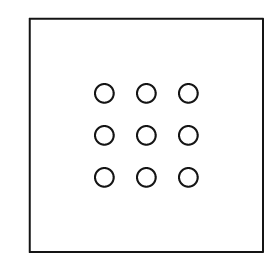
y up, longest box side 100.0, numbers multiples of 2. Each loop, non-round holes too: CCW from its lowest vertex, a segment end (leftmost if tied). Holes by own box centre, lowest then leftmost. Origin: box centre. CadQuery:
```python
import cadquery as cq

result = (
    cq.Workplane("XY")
    .moveTo(-50.0, -50.0)
    .lineTo(50.0, -50.0)
    .lineTo(50.0, 50.0)
    .lineTo(-50.0, 50.0)
    .close()
    .moveTo(-18.0, -18.0)
    .circle(4.0)
    .moveTo(0.0, -18.0)
    .circle(4.0)
    .moveTo(18.0, -18.0)
    .circle(4.0)
    .moveTo(-18.0, 0.0)
    .circle(4.0)
    .moveTo(0.0, 0.0)
    .circle(4.0)
    .moveTo(18.0, 0.0)
    .circle(4.0)
    .moveTo(-18.0, 18.0)
    .circle(4.0)
    .moveTo(0.0, 18.0)
    .circle(4.0)
    .moveTo(18.0, 18.0)
    .circle(4.0)
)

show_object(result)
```